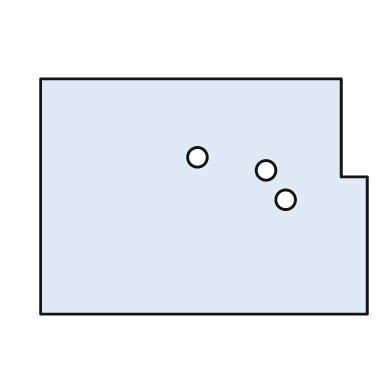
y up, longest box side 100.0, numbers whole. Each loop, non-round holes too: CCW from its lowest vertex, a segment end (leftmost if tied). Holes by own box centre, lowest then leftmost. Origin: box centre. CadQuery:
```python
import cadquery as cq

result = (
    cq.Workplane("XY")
    .moveTo(-50.0, -36.0)
    .lineTo(50.0, -36.0)
    .lineTo(50.0, 6.0)
    .lineTo(42.0, 6.0)
    .lineTo(42.0, 36.0)
    .lineTo(-50.0, 36.0)
    .close()
    .moveTo(25.0, -1.0)
    .circle(3.0)
    .moveTo(19.0, 8.0)
    .circle(3.0)
    .moveTo(-2.0, 12.0)
    .circle(3.0)
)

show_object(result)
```